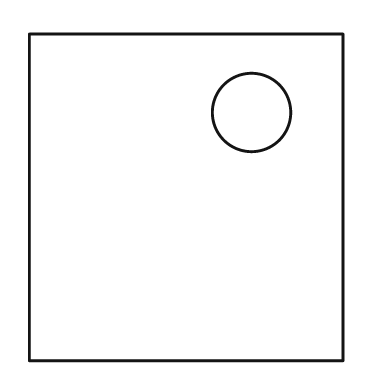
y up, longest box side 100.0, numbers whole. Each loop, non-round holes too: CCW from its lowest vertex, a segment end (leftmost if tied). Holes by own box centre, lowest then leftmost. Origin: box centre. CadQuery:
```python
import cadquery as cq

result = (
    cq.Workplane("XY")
    .moveTo(-48.0, -50.0)
    .lineTo(48.0, -50.0)
    .lineTo(48.0, 50.0)
    .lineTo(-48.0, 50.0)
    .close()
    .moveTo(20.0, 26.0)
    .circle(12.0)
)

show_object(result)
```